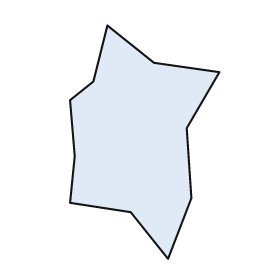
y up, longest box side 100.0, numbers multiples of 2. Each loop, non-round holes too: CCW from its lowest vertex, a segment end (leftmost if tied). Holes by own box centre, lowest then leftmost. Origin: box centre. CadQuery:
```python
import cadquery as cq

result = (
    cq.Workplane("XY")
    .moveTo(10.0, -50.0)
    .lineTo(20.0, -24.0)
    .lineTo(18.0, 6.0)
    .lineTo(32.0, 30.0)
    .lineTo(4.0, 34.0)
    .lineTo(-16.0, 50.0)
    .lineTo(-22.0, 26.0)
    .lineTo(-32.0, 18.0)
    .lineTo(-30.0, -6.0)
    .lineTo(-32.0, -26.0)
    .lineTo(-6.0, -30.0)
    .close()
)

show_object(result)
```